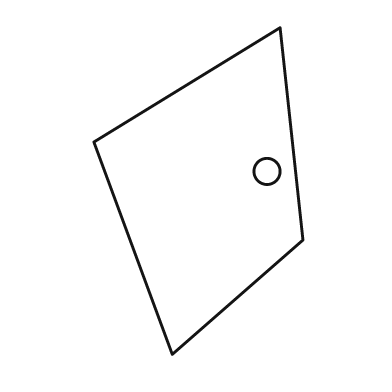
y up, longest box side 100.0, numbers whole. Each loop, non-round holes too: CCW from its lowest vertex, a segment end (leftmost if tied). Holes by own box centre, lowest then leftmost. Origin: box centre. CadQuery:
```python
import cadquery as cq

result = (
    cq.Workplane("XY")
    .moveTo(-8.0, -50.0)
    .lineTo(32.0, -15.0)
    .lineTo(25.0, 50.0)
    .lineTo(-32.0, 15.0)
    .close()
    .moveTo(21.0, 6.0)
    .circle(4.0)
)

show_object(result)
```